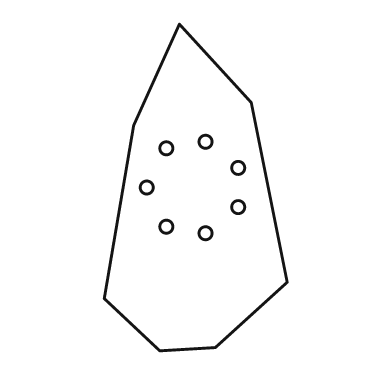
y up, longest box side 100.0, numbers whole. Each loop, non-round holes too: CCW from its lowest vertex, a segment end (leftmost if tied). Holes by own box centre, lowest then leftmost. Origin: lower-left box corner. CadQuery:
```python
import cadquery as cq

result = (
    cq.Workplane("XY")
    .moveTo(17.0, 0.0)
    .lineTo(34.0, 1.0)
    .lineTo(56.0, 21.0)
    .lineTo(45.0, 76.0)
    .lineTo(23.0, 100.0)
    .lineTo(9.0, 69.0)
    .lineTo(0.0, 16.0)
    .close()
    .moveTo(31.0, 36.0)
    .circle(2.0)
    .moveTo(19.0, 38.0)
    .circle(2.0)
    .moveTo(41.0, 44.0)
    .circle(2.0)
    .moveTo(13.0, 50.0)
    .circle(2.0)
    .moveTo(41.0, 56.0)
    .circle(2.0)
    .moveTo(19.0, 62.0)
    .circle(2.0)
    .moveTo(31.0, 64.0)
    .circle(2.0)
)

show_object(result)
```